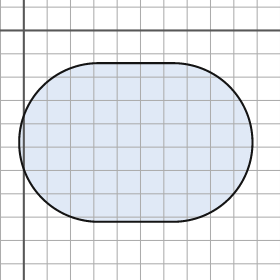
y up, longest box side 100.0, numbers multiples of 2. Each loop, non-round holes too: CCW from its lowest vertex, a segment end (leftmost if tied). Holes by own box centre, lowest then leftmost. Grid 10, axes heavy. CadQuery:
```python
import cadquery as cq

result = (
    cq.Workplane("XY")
    .moveTo(32.0, -82.0)
    .lineTo(64.0, -82.0)
    .threePointArc((98.0, -48.0), (64.0, -14.0))
    .lineTo(32.0, -14.0)
    .threePointArc((-2.0, -48.0), (32.0, -82.0))
    .close()
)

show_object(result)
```